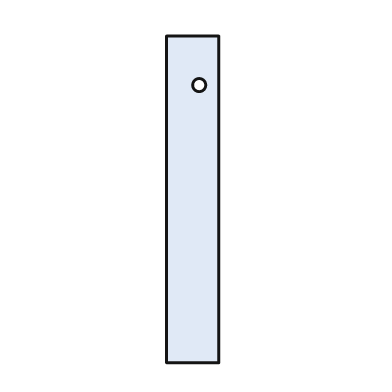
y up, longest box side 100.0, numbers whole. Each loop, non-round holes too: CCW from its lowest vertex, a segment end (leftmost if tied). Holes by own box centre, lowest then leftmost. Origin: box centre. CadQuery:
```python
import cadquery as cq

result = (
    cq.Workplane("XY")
    .moveTo(-8.0, -50.0)
    .lineTo(8.0, -50.0)
    .lineTo(8.0, 50.0)
    .lineTo(-8.0, 50.0)
    .close()
    .moveTo(2.0, 35.0)
    .circle(2.0)
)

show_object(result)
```